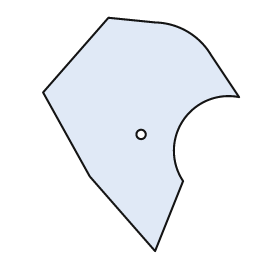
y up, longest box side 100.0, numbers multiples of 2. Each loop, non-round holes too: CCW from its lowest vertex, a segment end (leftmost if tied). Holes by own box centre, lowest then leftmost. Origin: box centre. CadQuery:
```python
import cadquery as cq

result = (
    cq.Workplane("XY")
    .moveTo(6.0, -50.0)
    .lineTo(18.0, -20.0)
    .threePointArc((18.0, 6.0), (42.0, 16.0))
    .lineTo(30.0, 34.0)
    .threePointArc((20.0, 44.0), (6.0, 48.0))
    .lineTo(-14.0, 50.0)
    .lineTo(-42.0, 18.0)
    .lineTo(-22.0, -18.0)
    .close()
    .moveTo(0.0, 0.0)
    .circle(2.0)
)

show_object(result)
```